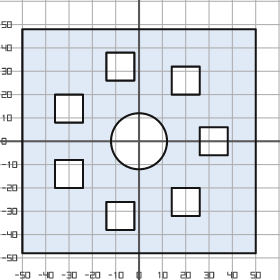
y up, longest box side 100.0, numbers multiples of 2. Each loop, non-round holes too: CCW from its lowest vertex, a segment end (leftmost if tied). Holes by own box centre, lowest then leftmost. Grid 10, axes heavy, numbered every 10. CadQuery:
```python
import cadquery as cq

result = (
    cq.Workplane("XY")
    .moveTo(-50.0, -48.0)
    .lineTo(50.0, -48.0)
    .lineTo(50.0, 48.0)
    .lineTo(-50.0, 48.0)
    .close()
    .moveTo(-14.0, -38.0)
    .lineTo(-2.0, -38.0)
    .lineTo(-2.0, -26.0)
    .lineTo(-14.0, -26.0)
    .close()
    .moveTo(14.0, -32.0)
    .lineTo(26.0, -32.0)
    .lineTo(26.0, -20.0)
    .lineTo(14.0, -20.0)
    .close()
    .moveTo(-36.0, -20.0)
    .lineTo(-24.0, -20.0)
    .lineTo(-24.0, -8.0)
    .lineTo(-36.0, -8.0)
    .close()
    .moveTo(0.0, 0.0)
    .circle(12.0)
    .moveTo(26.0, -6.0)
    .lineTo(38.0, -6.0)
    .lineTo(38.0, 6.0)
    .lineTo(26.0, 6.0)
    .close()
    .moveTo(-36.0, 8.0)
    .lineTo(-24.0, 8.0)
    .lineTo(-24.0, 20.0)
    .lineTo(-36.0, 20.0)
    .close()
    .moveTo(14.0, 20.0)
    .lineTo(26.0, 20.0)
    .lineTo(26.0, 32.0)
    .lineTo(14.0, 32.0)
    .close()
    .moveTo(-14.0, 26.0)
    .lineTo(-2.0, 26.0)
    .lineTo(-2.0, 38.0)
    .lineTo(-14.0, 38.0)
    .close()
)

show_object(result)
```